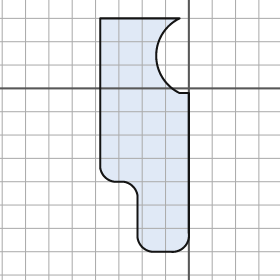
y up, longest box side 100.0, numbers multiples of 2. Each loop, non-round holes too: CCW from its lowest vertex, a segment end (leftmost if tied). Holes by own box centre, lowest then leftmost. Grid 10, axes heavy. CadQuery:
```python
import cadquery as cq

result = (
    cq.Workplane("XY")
    .moveTo(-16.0, -70.0)
    .lineTo(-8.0, -70.0)
    .threePointArc((-2.0, -68.0), (0.0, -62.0))
    .lineTo(0.0, -2.0)
    .lineTo(-4.0, -2.0)
    .threePointArc((-14.0, 14.0), (-4.0, 30.0))
    .lineTo(-38.0, 30.0)
    .lineTo(-38.0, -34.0)
    .threePointArc((-36.0, -38.0), (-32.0, -40.0))
    .lineTo(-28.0, -40.0)
    .threePointArc((-24.0, -42.0), (-22.0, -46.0))
    .lineTo(-22.0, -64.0)
    .threePointArc((-20.0, -68.0), (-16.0, -70.0))
    .close()
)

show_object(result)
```